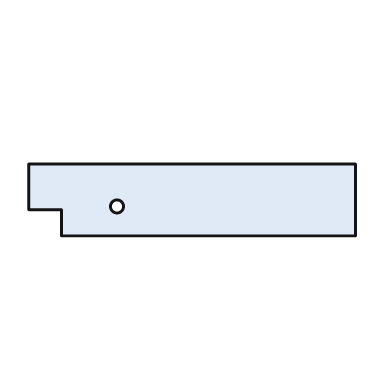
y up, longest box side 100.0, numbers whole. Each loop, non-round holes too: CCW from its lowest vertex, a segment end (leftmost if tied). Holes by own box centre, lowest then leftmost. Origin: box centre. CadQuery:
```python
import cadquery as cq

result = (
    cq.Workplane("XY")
    .moveTo(-40.0, -11.0)
    .lineTo(50.0, -11.0)
    .lineTo(50.0, 11.0)
    .lineTo(-50.0, 11.0)
    .lineTo(-50.0, -3.0)
    .lineTo(-40.0, -3.0)
    .close()
    .moveTo(-23.0, -2.0)
    .circle(2.0)
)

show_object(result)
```